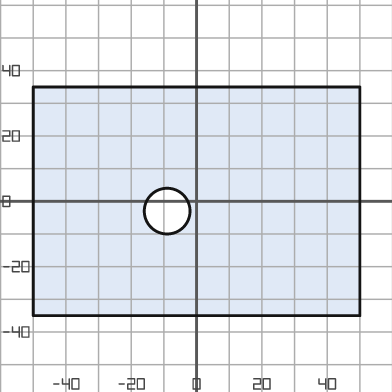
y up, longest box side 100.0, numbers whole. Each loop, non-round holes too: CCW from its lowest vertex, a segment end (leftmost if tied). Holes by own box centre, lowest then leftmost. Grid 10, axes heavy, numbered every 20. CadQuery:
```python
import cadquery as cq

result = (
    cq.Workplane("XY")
    .moveTo(-50.0, -35.0)
    .lineTo(50.0, -35.0)
    .lineTo(50.0, 35.0)
    .lineTo(-50.0, 35.0)
    .close()
    .moveTo(-9.0, -3.0)
    .circle(7.0)
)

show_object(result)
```